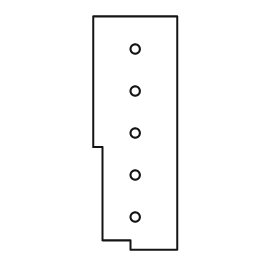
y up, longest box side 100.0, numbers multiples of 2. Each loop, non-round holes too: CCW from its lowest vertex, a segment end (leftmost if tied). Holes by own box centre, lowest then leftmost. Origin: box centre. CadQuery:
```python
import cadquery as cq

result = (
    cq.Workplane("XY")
    .moveTo(-2.0, -50.0)
    .lineTo(18.0, -50.0)
    .lineTo(18.0, 50.0)
    .lineTo(-18.0, 50.0)
    .lineTo(-18.0, -6.0)
    .lineTo(-14.0, -6.0)
    .lineTo(-14.0, -46.0)
    .lineTo(-2.0, -46.0)
    .close()
    .moveTo(0.0, -36.0)
    .circle(2.0)
    .moveTo(0.0, -18.0)
    .circle(2.0)
    .moveTo(0.0, 0.0)
    .circle(2.0)
    .moveTo(0.0, 18.0)
    .circle(2.0)
    .moveTo(0.0, 36.0)
    .circle(2.0)
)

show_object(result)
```